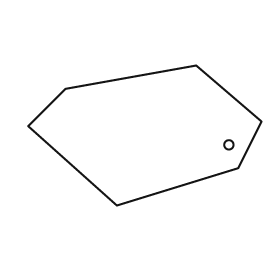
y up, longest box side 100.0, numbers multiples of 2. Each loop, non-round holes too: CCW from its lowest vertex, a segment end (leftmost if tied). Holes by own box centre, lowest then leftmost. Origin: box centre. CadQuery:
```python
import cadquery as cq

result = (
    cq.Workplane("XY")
    .moveTo(-12.0, -30.0)
    .lineTo(40.0, -14.0)
    .lineTo(50.0, 6.0)
    .lineTo(22.0, 30.0)
    .lineTo(-34.0, 20.0)
    .lineTo(-50.0, 4.0)
    .close()
    .moveTo(36.0, -4.0)
    .circle(2.0)
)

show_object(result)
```